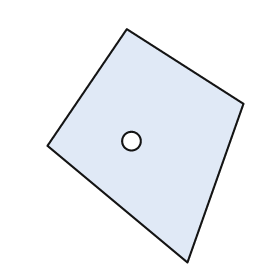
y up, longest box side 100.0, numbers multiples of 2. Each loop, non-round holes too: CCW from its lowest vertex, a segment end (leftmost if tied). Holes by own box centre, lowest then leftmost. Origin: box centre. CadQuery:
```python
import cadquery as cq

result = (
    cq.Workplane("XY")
    .moveTo(18.0, -50.0)
    .lineTo(42.0, 18.0)
    .lineTo(-8.0, 50.0)
    .lineTo(-42.0, 0.0)
    .close()
    .moveTo(-6.0, 2.0)
    .circle(4.0)
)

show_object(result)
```